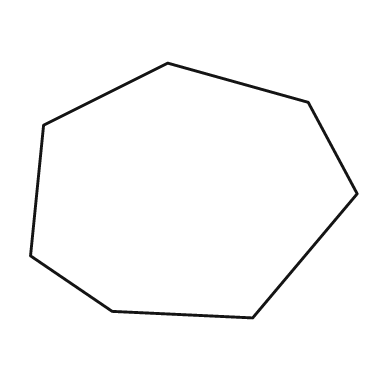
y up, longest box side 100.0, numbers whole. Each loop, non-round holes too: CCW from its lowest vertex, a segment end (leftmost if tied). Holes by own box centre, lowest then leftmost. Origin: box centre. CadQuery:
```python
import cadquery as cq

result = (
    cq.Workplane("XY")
    .moveTo(18.0, -39.0)
    .lineTo(50.0, -1.0)
    .lineTo(35.0, 27.0)
    .lineTo(-8.0, 39.0)
    .lineTo(-46.0, 20.0)
    .lineTo(-50.0, -20.0)
    .lineTo(-25.0, -37.0)
    .close()
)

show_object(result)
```